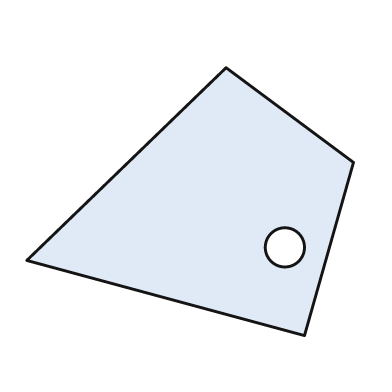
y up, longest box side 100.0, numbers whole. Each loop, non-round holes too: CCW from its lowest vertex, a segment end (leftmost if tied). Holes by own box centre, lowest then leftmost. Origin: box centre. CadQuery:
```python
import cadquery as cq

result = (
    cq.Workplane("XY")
    .moveTo(35.0, -41.0)
    .lineTo(50.0, 12.0)
    .lineTo(11.0, 41.0)
    .lineTo(-50.0, -18.0)
    .close()
    .moveTo(29.0, -14.0)
    .circle(6.0)
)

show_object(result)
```